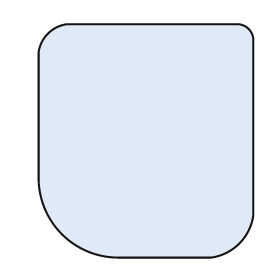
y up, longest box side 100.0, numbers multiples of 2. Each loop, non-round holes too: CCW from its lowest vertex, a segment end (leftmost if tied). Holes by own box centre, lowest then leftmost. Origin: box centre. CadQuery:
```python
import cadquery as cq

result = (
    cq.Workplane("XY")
    .moveTo(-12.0, -50.0)
    .lineTo(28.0, -50.0)
    .threePointArc((40.0, -44.0), (46.0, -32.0))
    .lineTo(46.0, 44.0)
    .threePointArc((44.0, 48.0), (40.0, 50.0))
    .lineTo(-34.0, 50.0)
    .threePointArc((-42.0, 46.0), (-46.0, 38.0))
    .lineTo(-46.0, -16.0)
    .threePointArc((-36.0, -40.0), (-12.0, -50.0))
    .close()
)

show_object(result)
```